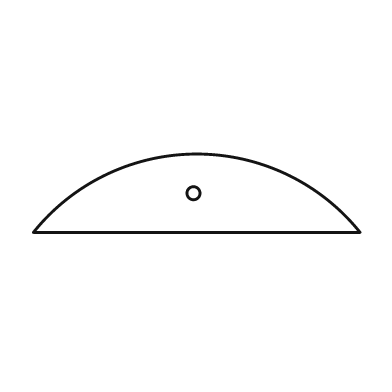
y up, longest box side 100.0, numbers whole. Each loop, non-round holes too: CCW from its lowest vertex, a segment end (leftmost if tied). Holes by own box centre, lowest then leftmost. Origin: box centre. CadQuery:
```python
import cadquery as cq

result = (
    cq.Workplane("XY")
    .moveTo(-50.0, -12.0)
    .lineTo(50.0, -12.0)
    .threePointArc((0.0, 12.0), (-50.0, -12.0))
    .close()
    .moveTo(-1.0, 0.0)
    .circle(2.0)
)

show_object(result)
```